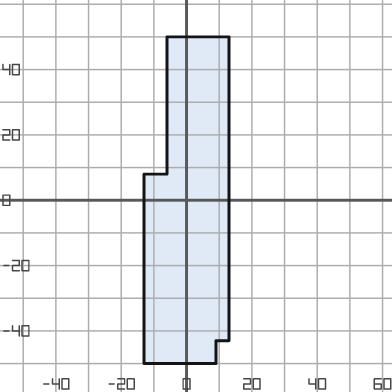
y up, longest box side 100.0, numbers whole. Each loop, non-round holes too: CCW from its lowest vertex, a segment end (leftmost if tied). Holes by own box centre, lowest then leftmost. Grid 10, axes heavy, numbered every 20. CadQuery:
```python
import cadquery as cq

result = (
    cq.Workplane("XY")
    .moveTo(-13.0, -50.0)
    .lineTo(9.0, -50.0)
    .lineTo(9.0, -43.0)
    .lineTo(13.0, -43.0)
    .lineTo(13.0, 50.0)
    .lineTo(-6.0, 50.0)
    .lineTo(-6.0, 8.0)
    .lineTo(-13.0, 8.0)
    .close()
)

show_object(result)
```